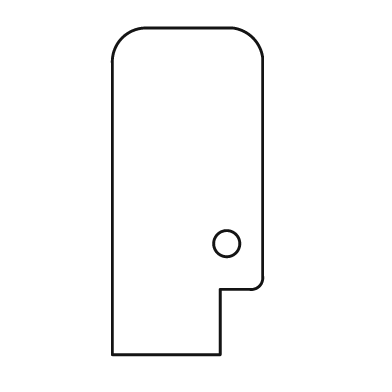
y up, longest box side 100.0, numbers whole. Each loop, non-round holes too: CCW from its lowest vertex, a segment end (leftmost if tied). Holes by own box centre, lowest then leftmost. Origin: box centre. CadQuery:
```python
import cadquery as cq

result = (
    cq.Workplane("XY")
    .moveTo(-23.0, -50.0)
    .lineTo(10.0, -50.0)
    .lineTo(10.0, -30.0)
    .lineTo(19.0, -30.0)
    .threePointArc((22.0, -29.0), (23.0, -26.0))
    .lineTo(23.0, 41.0)
    .threePointArc((20.0, 47.0), (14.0, 50.0))
    .lineTo(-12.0, 50.0)
    .threePointArc((-20.0, 47.0), (-23.0, 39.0))
    .close()
    .moveTo(12.0, -16.0)
    .circle(4.0)
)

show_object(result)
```